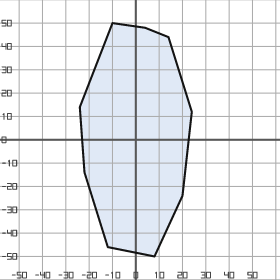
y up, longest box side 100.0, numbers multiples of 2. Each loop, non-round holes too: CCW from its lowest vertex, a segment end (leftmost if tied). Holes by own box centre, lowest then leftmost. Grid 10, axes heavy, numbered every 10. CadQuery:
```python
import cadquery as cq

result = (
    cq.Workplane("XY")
    .moveTo(8.0, -50.0)
    .lineTo(20.0, -24.0)
    .lineTo(24.0, 12.0)
    .lineTo(14.0, 44.0)
    .lineTo(4.0, 48.0)
    .lineTo(-10.0, 50.0)
    .lineTo(-24.0, 14.0)
    .lineTo(-22.0, -14.0)
    .lineTo(-12.0, -46.0)
    .close()
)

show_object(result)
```